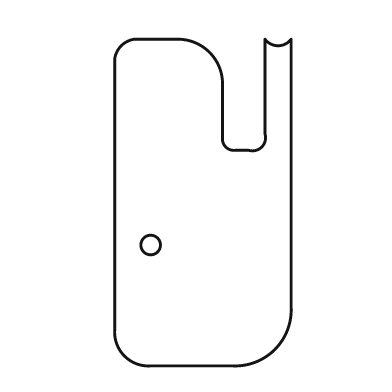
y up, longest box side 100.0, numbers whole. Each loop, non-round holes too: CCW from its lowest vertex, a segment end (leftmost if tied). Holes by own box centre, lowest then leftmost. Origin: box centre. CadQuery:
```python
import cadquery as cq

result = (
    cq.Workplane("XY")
    .moveTo(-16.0, -50.0)
    .lineTo(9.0, -50.0)
    .threePointArc((22.0, -45.0), (27.0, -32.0))
    .lineTo(27.0, 50.0)
    .threePointArc((23.0, 48.0), (19.0, 50.0))
    .lineTo(19.0, 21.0)
    .threePointArc((18.0, 17.0), (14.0, 16.0))
    .lineTo(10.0, 16.0)
    .threePointArc((7.0, 17.0), (6.0, 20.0))
    .lineTo(6.0, 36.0)
    .threePointArc((2.0, 46.0), (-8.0, 50.0))
    .lineTo(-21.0, 50.0)
    .threePointArc((-25.0, 48.0), (-27.0, 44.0))
    .lineTo(-27.0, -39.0)
    .threePointArc((-24.0, -47.0), (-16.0, -50.0))
    .close()
    .moveTo(-16.0, -13.0)
    .circle(3.0)
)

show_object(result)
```